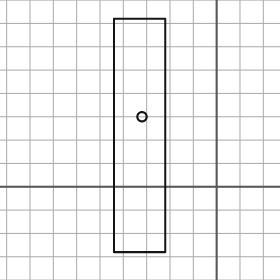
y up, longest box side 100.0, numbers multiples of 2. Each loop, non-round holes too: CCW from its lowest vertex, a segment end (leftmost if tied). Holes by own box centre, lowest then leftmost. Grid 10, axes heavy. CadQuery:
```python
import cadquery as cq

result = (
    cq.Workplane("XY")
    .moveTo(-44.0, -28.0)
    .lineTo(-22.0, -28.0)
    .lineTo(-22.0, 72.0)
    .lineTo(-44.0, 72.0)
    .close()
    .moveTo(-32.0, 30.0)
    .circle(2.0)
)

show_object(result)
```